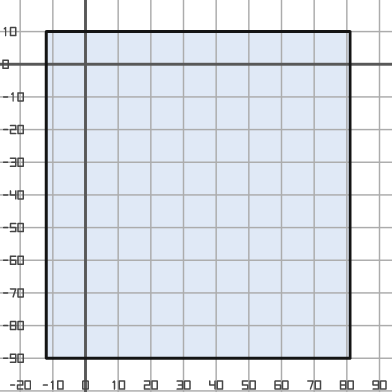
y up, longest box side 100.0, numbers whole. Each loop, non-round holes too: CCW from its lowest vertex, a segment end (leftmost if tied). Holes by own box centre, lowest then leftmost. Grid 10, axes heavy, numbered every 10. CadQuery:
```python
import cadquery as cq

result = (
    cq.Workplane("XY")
    .moveTo(-12.0, -90.0)
    .lineTo(81.0, -90.0)
    .lineTo(81.0, 10.0)
    .lineTo(-12.0, 10.0)
    .close()
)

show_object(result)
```